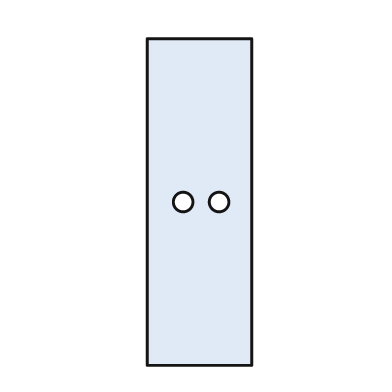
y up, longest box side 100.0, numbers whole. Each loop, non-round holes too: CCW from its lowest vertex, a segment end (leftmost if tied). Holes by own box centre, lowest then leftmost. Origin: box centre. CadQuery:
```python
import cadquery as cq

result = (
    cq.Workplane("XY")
    .moveTo(-16.0, -50.0)
    .lineTo(16.0, -50.0)
    .lineTo(16.0, 50.0)
    .lineTo(-16.0, 50.0)
    .close()
    .moveTo(-5.0, 0.0)
    .circle(3.0)
    .moveTo(6.0, 0.0)
    .circle(3.0)
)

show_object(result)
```